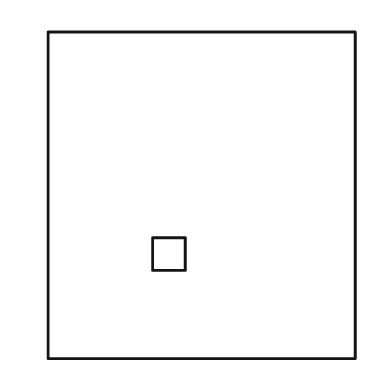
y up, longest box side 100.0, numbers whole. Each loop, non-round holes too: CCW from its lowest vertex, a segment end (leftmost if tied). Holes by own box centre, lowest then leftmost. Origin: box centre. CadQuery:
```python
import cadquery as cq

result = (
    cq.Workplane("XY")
    .moveTo(-47.0, -50.0)
    .lineTo(47.0, -50.0)
    .lineTo(47.0, 50.0)
    .lineTo(-47.0, 50.0)
    .close()
    .moveTo(-15.0, -23.0)
    .lineTo(-5.0, -23.0)
    .lineTo(-5.0, -13.0)
    .lineTo(-15.0, -13.0)
    .close()
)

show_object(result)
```